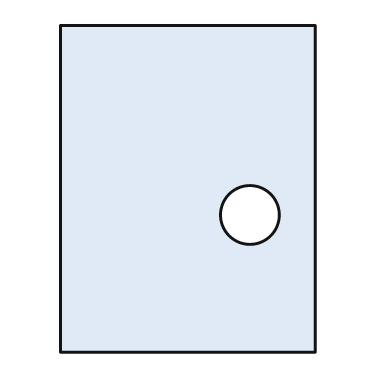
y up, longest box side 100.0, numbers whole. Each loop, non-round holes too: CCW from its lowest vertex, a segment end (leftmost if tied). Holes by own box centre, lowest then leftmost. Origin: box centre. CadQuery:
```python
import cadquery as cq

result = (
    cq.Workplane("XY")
    .moveTo(-39.0, -50.0)
    .lineTo(39.0, -50.0)
    .lineTo(39.0, 50.0)
    .lineTo(-39.0, 50.0)
    .close()
    .moveTo(19.0, -8.0)
    .circle(9.0)
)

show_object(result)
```